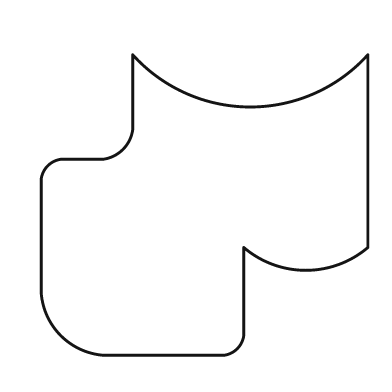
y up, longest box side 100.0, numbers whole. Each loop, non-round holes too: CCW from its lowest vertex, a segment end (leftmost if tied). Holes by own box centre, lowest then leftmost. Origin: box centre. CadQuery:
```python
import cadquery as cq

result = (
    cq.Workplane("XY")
    .moveTo(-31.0, -46.0)
    .lineTo(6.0, -46.0)
    .threePointArc((10.0, -44.0), (12.0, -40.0))
    .lineTo(12.0, -13.0)
    .threePointArc((31.0, -20.0), (50.0, -13.0))
    .lineTo(50.0, 46.0)
    .threePointArc((14.0, 30.0), (-22.0, 46.0))
    .lineTo(-22.0, 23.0)
    .threePointArc((-25.0, 17.0), (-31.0, 14.0))
    .lineTo(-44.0, 14.0)
    .threePointArc((-48.0, 12.0), (-50.0, 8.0))
    .lineTo(-50.0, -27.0)
    .threePointArc((-44.0, -40.0), (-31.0, -46.0))
    .close()
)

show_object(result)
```